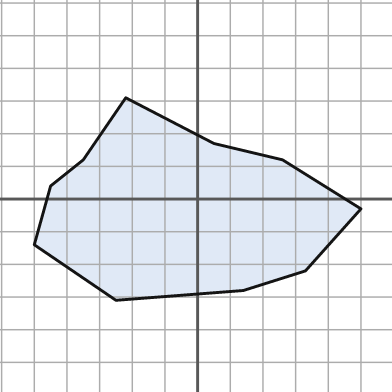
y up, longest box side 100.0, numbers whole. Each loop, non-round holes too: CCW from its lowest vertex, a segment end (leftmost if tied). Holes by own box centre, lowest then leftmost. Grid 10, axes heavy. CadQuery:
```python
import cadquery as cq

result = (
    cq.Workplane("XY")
    .moveTo(-25.0, -31.0)
    .lineTo(14.0, -28.0)
    .lineTo(33.0, -22.0)
    .lineTo(50.0, -3.0)
    .lineTo(26.0, 12.0)
    .lineTo(5.0, 17.0)
    .lineTo(-22.0, 31.0)
    .lineTo(-35.0, 12.0)
    .lineTo(-45.0, 4.0)
    .lineTo(-50.0, -14.0)
    .close()
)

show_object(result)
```